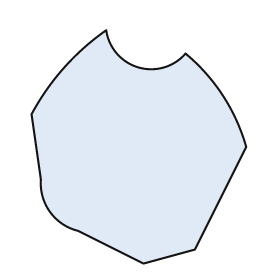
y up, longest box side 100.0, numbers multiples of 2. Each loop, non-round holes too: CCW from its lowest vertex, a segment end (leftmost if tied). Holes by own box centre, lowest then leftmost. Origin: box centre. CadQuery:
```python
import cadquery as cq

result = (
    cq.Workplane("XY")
    .moveTo(2.0, -50.0)
    .lineTo(24.0, -44.0)
    .lineTo(46.0, 0.0)
    .threePointArc((36.0, 22.0), (20.0, 40.0))
    .threePointArc((0.0, 34.0), (-14.0, 50.0))
    .threePointArc((-32.0, 34.0), (-46.0, 14.0))
    .lineTo(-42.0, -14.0)
    .threePointArc((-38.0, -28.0), (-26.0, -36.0))
    .close()
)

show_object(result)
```